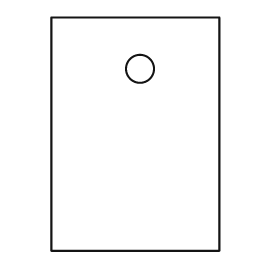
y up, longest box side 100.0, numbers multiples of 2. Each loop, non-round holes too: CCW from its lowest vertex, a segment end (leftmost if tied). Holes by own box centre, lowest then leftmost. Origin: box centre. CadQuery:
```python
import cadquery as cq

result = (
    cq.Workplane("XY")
    .moveTo(-36.0, -50.0)
    .lineTo(36.0, -50.0)
    .lineTo(36.0, 50.0)
    .lineTo(-36.0, 50.0)
    .close()
    .moveTo(2.0, 28.0)
    .circle(6.0)
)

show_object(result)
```